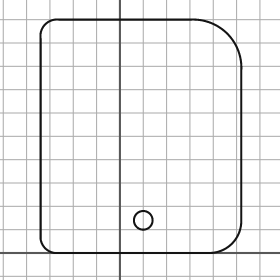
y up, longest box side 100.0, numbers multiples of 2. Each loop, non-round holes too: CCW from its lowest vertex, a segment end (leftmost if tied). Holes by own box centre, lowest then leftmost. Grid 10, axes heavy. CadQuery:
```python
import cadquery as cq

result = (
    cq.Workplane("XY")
    .moveTo(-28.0, 0.0)
    .lineTo(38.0, 0.0)
    .threePointArc((48.0, 4.0), (52.0, 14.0))
    .lineTo(52.0, 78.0)
    .threePointArc((46.0, 94.0), (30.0, 100.0))
    .lineTo(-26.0, 100.0)
    .threePointArc((-32.0, 98.0), (-34.0, 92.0))
    .lineTo(-34.0, 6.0)
    .threePointArc((-32.0, 2.0), (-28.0, 0.0))
    .close()
    .moveTo(10.0, 14.0)
    .circle(4.0)
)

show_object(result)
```